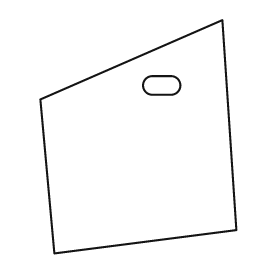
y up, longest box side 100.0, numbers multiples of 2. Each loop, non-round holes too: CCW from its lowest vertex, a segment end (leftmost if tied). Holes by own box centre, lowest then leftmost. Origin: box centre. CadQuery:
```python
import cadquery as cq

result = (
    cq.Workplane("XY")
    .moveTo(-36.0, -50.0)
    .lineTo(42.0, -40.0)
    .lineTo(36.0, 50.0)
    .lineTo(-42.0, 16.0)
    .close()
    .moveTo(6.0, 18.0)
    .lineTo(14.0, 18.0)
    .threePointArc((18.0, 22.0), (14.0, 26.0))
    .lineTo(6.0, 26.0)
    .threePointArc((2.0, 22.0), (6.0, 18.0))
    .close()
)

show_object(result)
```